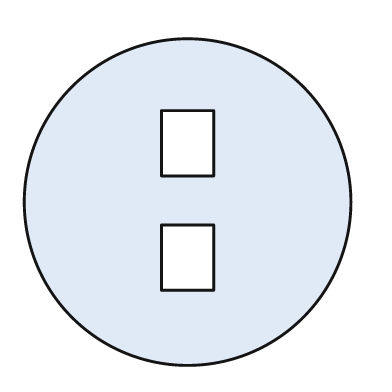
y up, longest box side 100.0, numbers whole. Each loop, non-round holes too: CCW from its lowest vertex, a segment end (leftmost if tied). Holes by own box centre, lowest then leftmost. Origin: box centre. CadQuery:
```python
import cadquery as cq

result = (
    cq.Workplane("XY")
    .moveTo(0.0, 0.0)
    .circle(50.0)
    .moveTo(-8.0, -27.0)
    .lineTo(8.0, -27.0)
    .lineTo(8.0, -7.0)
    .lineTo(-8.0, -7.0)
    .close()
    .moveTo(-8.0, 8.0)
    .lineTo(8.0, 8.0)
    .lineTo(8.0, 28.0)
    .lineTo(-8.0, 28.0)
    .close()
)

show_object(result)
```